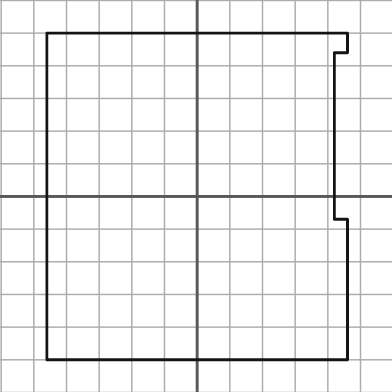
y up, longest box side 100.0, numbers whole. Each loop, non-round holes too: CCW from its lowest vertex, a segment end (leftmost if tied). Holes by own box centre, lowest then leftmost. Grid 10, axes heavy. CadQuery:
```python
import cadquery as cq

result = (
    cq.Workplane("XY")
    .moveTo(-46.0, -50.0)
    .lineTo(46.0, -50.0)
    .lineTo(46.0, -7.0)
    .lineTo(42.0, -7.0)
    .lineTo(42.0, 44.0)
    .lineTo(46.0, 44.0)
    .lineTo(46.0, 50.0)
    .lineTo(-46.0, 50.0)
    .close()
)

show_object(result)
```